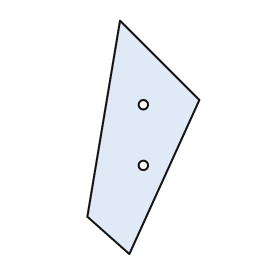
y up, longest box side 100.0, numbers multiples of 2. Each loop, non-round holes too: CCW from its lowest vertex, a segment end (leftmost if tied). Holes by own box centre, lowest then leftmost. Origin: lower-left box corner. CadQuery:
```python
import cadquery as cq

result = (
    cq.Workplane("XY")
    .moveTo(18.0, 0.0)
    .lineTo(48.0, 66.0)
    .lineTo(14.0, 100.0)
    .lineTo(0.0, 16.0)
    .close()
    .moveTo(24.0, 38.0)
    .circle(2.0)
    .moveTo(24.0, 64.0)
    .circle(2.0)
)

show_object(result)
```